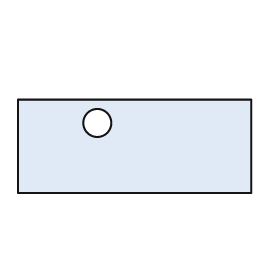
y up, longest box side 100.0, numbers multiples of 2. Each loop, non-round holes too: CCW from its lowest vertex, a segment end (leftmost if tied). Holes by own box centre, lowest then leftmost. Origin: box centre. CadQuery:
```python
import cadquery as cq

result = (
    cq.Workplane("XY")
    .moveTo(-50.0, -20.0)
    .lineTo(50.0, -20.0)
    .lineTo(50.0, 20.0)
    .lineTo(-50.0, 20.0)
    .close()
    .moveTo(-16.0, 10.0)
    .circle(6.0)
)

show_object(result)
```